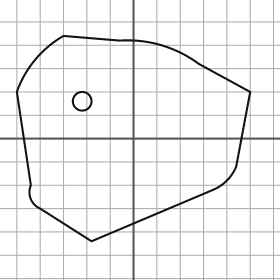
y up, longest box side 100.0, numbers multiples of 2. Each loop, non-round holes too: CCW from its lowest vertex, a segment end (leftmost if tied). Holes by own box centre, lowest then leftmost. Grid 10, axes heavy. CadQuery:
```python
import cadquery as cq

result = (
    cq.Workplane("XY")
    .moveTo(-18.0, -44.0)
    .lineTo(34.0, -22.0)
    .threePointArc((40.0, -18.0), (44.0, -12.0))
    .lineTo(50.0, 20.0)
    .lineTo(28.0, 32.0)
    .threePointArc((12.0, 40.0), (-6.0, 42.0))
    .lineTo(-30.0, 44.0)
    .threePointArc((-42.0, 34.0), (-50.0, 20.0))
    .lineTo(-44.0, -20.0)
    .threePointArc((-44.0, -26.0), (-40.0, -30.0))
    .close()
    .moveTo(-22.0, 16.0)
    .circle(4.0)
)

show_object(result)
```